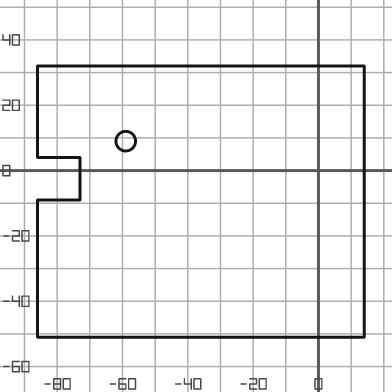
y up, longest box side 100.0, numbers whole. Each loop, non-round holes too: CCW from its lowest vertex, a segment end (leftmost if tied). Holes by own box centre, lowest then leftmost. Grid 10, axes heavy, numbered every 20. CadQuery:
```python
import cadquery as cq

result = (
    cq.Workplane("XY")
    .moveTo(-86.0, -51.0)
    .lineTo(14.0, -51.0)
    .lineTo(14.0, 32.0)
    .lineTo(-86.0, 32.0)
    .lineTo(-86.0, 4.0)
    .lineTo(-73.0, 4.0)
    .lineTo(-73.0, -9.0)
    .lineTo(-86.0, -9.0)
    .close()
    .moveTo(-59.0, 9.0)
    .circle(3.0)
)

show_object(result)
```